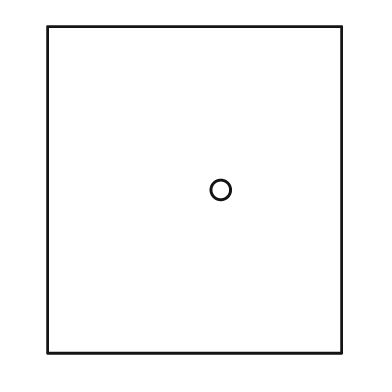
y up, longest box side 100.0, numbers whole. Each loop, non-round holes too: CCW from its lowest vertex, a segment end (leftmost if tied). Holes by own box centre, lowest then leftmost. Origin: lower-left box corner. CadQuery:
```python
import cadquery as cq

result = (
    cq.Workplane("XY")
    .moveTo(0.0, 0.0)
    .lineTo(90.0, 0.0)
    .lineTo(90.0, 100.0)
    .lineTo(0.0, 100.0)
    .close()
    .moveTo(53.0, 50.0)
    .circle(3.0)
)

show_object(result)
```